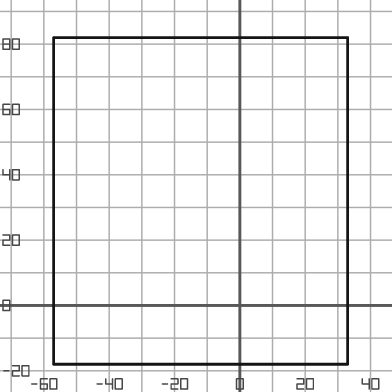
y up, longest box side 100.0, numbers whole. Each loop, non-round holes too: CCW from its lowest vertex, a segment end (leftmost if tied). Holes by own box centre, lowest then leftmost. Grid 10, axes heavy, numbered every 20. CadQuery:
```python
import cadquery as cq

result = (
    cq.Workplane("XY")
    .moveTo(-57.0, -18.0)
    .lineTo(33.0, -18.0)
    .lineTo(33.0, 82.0)
    .lineTo(-57.0, 82.0)
    .close()
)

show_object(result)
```